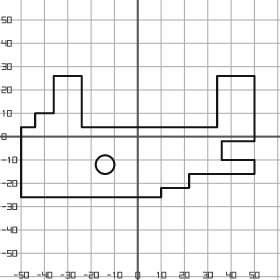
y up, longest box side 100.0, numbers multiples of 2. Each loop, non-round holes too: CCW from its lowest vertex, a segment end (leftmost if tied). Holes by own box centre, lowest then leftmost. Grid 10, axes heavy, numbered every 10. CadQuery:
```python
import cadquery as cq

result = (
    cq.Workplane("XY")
    .moveTo(-50.0, -26.0)
    .lineTo(10.0, -26.0)
    .lineTo(10.0, -22.0)
    .lineTo(22.0, -22.0)
    .lineTo(22.0, -16.0)
    .lineTo(50.0, -16.0)
    .lineTo(50.0, -10.0)
    .lineTo(36.0, -10.0)
    .lineTo(36.0, -2.0)
    .lineTo(50.0, -2.0)
    .lineTo(50.0, 26.0)
    .lineTo(34.0, 26.0)
    .lineTo(34.0, 4.0)
    .lineTo(-24.0, 4.0)
    .lineTo(-24.0, 26.0)
    .lineTo(-36.0, 26.0)
    .lineTo(-36.0, 10.0)
    .lineTo(-44.0, 10.0)
    .lineTo(-44.0, 4.0)
    .lineTo(-50.0, 4.0)
    .close()
    .moveTo(-14.0, -12.0)
    .circle(4.0)
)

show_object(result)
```